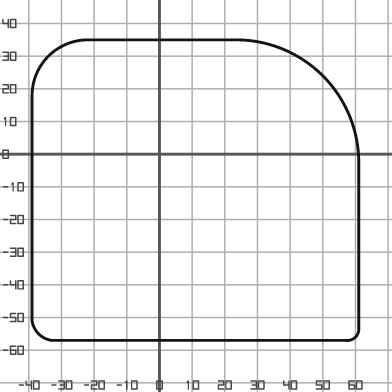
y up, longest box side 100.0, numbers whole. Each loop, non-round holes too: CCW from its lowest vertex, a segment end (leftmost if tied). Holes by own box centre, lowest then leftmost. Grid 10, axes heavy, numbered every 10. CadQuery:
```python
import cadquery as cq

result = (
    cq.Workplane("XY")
    .moveTo(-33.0, -57.0)
    .lineTo(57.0, -57.0)
    .threePointArc((60.0, -56.0), (61.0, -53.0))
    .lineTo(61.0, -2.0)
    .threePointArc((50.0, 24.0), (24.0, 35.0))
    .lineTo(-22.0, 35.0)
    .threePointArc((-34.0, 30.0), (-39.0, 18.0))
    .lineTo(-39.0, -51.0)
    .threePointArc((-37.0, -55.0), (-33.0, -57.0))
    .close()
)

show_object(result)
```